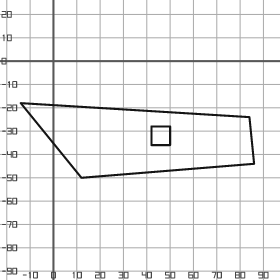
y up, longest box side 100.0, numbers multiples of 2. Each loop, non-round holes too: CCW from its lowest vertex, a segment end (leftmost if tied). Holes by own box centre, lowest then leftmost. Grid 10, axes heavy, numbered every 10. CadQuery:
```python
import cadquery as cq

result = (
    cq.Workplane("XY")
    .moveTo(12.0, -50.0)
    .lineTo(86.0, -44.0)
    .lineTo(84.0, -24.0)
    .lineTo(-14.0, -18.0)
    .close()
    .moveTo(42.0, -36.0)
    .lineTo(50.0, -36.0)
    .lineTo(50.0, -28.0)
    .lineTo(42.0, -28.0)
    .close()
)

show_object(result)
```